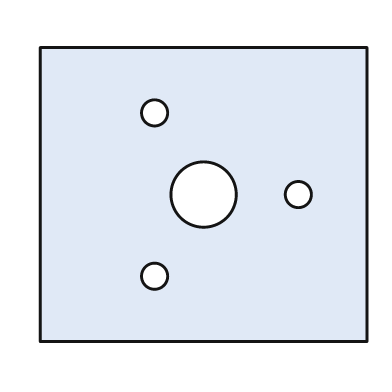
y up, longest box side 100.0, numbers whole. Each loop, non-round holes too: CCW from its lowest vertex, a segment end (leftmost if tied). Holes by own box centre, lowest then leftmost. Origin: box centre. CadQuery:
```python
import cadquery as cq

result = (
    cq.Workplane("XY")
    .moveTo(-50.0, -45.0)
    .lineTo(50.0, -45.0)
    .lineTo(50.0, 45.0)
    .lineTo(-50.0, 45.0)
    .close()
    .moveTo(-15.0, -25.0)
    .circle(4.0)
    .moveTo(0.0, 0.0)
    .circle(10.0)
    .moveTo(29.0, 0.0)
    .circle(4.0)
    .moveTo(-15.0, 25.0)
    .circle(4.0)
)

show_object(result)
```